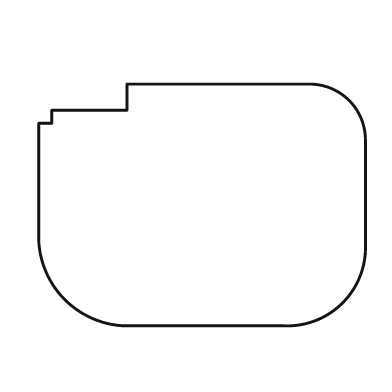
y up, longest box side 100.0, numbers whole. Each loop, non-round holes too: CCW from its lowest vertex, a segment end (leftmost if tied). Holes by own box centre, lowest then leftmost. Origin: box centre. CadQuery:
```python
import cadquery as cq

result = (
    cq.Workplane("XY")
    .moveTo(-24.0, -37.0)
    .lineTo(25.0, -37.0)
    .threePointArc((43.0, -30.0), (50.0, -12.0))
    .lineTo(50.0, 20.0)
    .threePointArc((45.0, 32.0), (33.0, 37.0))
    .lineTo(-23.0, 37.0)
    .lineTo(-23.0, 29.0)
    .lineTo(-46.0, 29.0)
    .lineTo(-46.0, 25.0)
    .lineTo(-50.0, 25.0)
    .lineTo(-50.0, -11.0)
    .threePointArc((-42.0, -29.0), (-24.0, -37.0))
    .close()
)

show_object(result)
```